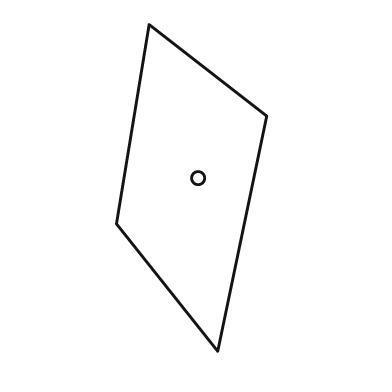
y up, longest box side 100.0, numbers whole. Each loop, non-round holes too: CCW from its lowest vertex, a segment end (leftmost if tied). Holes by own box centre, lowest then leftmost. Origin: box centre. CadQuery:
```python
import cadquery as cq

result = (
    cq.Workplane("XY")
    .moveTo(8.0, -50.0)
    .lineTo(23.0, 22.0)
    .lineTo(-13.0, 50.0)
    .lineTo(-23.0, -11.0)
    .close()
    .moveTo(2.0, 3.0)
    .circle(2.0)
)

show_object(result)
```